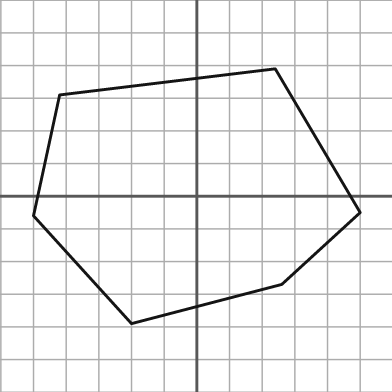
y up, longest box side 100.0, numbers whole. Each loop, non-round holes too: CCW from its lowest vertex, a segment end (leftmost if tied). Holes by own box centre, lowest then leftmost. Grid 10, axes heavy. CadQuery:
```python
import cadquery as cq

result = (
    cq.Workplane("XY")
    .moveTo(-20.0, -39.0)
    .lineTo(26.0, -27.0)
    .lineTo(50.0, -5.0)
    .lineTo(24.0, 39.0)
    .lineTo(-42.0, 31.0)
    .lineTo(-50.0, -6.0)
    .close()
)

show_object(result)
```